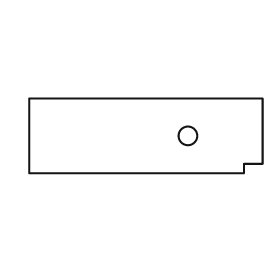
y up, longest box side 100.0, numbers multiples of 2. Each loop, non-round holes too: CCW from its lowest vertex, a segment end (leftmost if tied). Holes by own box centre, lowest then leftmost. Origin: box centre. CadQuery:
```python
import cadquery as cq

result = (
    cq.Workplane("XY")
    .moveTo(-50.0, -16.0)
    .lineTo(42.0, -16.0)
    .lineTo(42.0, -12.0)
    .lineTo(50.0, -12.0)
    .lineTo(50.0, 16.0)
    .lineTo(-50.0, 16.0)
    .close()
    .moveTo(18.0, 0.0)
    .circle(4.0)
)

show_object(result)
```